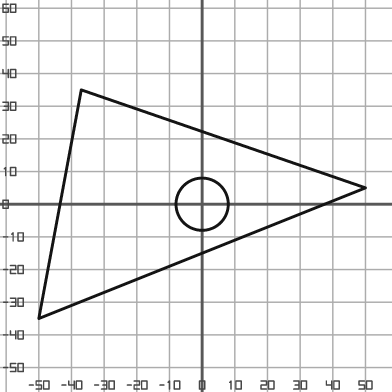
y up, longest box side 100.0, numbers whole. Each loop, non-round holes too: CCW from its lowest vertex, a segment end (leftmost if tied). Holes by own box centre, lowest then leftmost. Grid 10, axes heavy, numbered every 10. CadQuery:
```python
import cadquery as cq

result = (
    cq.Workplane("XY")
    .moveTo(-50.0, -35.0)
    .lineTo(50.0, 5.0)
    .lineTo(-37.0, 35.0)
    .close()
    .moveTo(0.0, 0.0)
    .circle(8.0)
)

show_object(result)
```